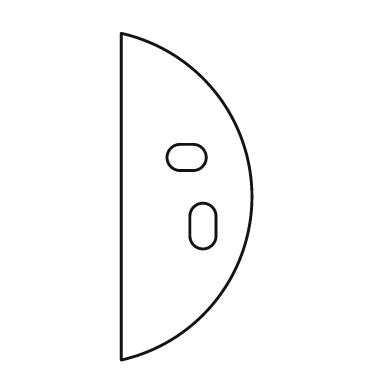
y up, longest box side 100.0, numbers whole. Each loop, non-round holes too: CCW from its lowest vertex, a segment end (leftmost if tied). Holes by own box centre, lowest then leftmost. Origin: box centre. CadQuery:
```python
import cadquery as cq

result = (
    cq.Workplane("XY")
    .moveTo(-20.0, -50.0)
    .threePointArc((20.0, 0.0), (-20.0, 50.0))
    .close()
    .moveTo(1.0, -12.0)
    .threePointArc((5.0, -16.0), (9.0, -12.0))
    .lineTo(9.0, -6.0)
    .threePointArc((5.0, -2.0), (1.0, -6.0))
    .close()
    .moveTo(-2.0, 8.0)
    .lineTo(2.0, 8.0)
    .threePointArc((6.0, 12.0), (2.0, 16.0))
    .lineTo(-2.0, 16.0)
    .threePointArc((-6.0, 12.0), (-2.0, 8.0))
    .close()
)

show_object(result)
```